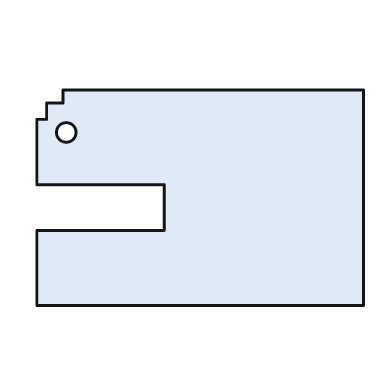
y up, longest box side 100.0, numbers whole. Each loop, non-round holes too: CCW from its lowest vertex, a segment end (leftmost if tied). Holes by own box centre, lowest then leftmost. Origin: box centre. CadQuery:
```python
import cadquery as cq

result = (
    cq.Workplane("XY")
    .moveTo(-50.0, -33.0)
    .lineTo(50.0, -33.0)
    .lineTo(50.0, 33.0)
    .lineTo(-42.0, 33.0)
    .lineTo(-42.0, 29.0)
    .lineTo(-47.0, 29.0)
    .lineTo(-47.0, 24.0)
    .lineTo(-50.0, 24.0)
    .lineTo(-50.0, 4.0)
    .lineTo(-11.0, 4.0)
    .lineTo(-11.0, -10.0)
    .lineTo(-50.0, -10.0)
    .close()
    .moveTo(-41.0, 20.0)
    .circle(3.0)
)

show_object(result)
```